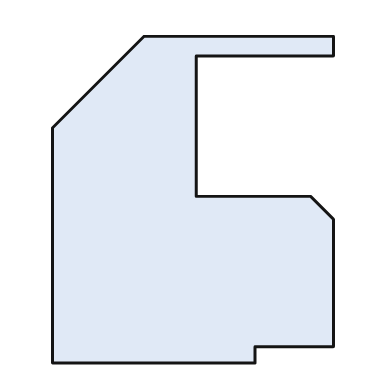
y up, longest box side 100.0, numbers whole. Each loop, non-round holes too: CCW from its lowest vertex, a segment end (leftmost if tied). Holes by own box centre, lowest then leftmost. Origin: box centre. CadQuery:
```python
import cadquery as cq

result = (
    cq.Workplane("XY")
    .moveTo(-43.0, -50.0)
    .lineTo(19.0, -50.0)
    .lineTo(19.0, -45.0)
    .lineTo(43.0, -45.0)
    .lineTo(43.0, -6.0)
    .lineTo(36.0, 1.0)
    .lineTo(1.0, 1.0)
    .lineTo(1.0, 44.0)
    .lineTo(43.0, 44.0)
    .lineTo(43.0, 50.0)
    .lineTo(-15.0, 50.0)
    .lineTo(-43.0, 22.0)
    .close()
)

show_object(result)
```